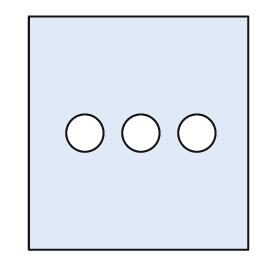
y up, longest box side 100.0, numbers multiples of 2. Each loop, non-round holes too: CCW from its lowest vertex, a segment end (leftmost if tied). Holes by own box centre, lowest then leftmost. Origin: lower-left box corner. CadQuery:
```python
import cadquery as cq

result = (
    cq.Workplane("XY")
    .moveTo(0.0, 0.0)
    .lineTo(94.0, 0.0)
    .lineTo(94.0, 100.0)
    .lineTo(0.0, 100.0)
    .close()
    .moveTo(24.0, 50.0)
    .circle(8.0)
    .moveTo(48.0, 50.0)
    .circle(8.0)
    .moveTo(72.0, 50.0)
    .circle(8.0)
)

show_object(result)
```